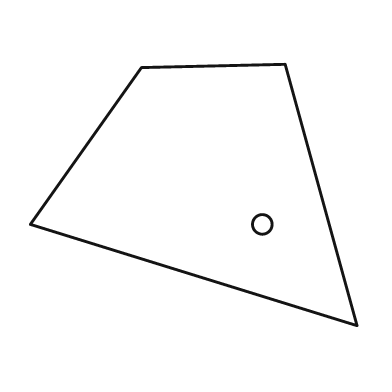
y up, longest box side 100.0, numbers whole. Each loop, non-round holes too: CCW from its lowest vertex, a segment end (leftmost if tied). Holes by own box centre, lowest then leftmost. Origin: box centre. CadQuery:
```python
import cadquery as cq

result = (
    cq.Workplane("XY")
    .moveTo(50.0, -40.0)
    .lineTo(28.0, 40.0)
    .lineTo(-16.0, 39.0)
    .lineTo(-50.0, -9.0)
    .close()
    .moveTo(21.0, -9.0)
    .circle(3.0)
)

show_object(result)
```